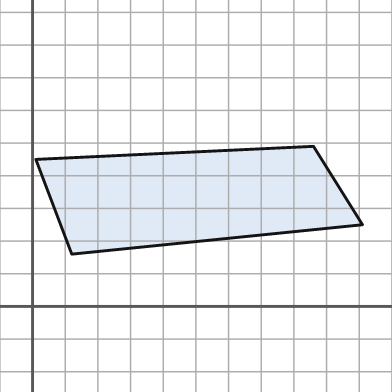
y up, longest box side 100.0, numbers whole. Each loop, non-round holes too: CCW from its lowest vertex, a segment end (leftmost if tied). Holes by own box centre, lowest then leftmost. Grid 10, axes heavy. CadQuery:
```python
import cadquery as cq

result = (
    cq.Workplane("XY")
    .moveTo(12.0, 16.0)
    .lineTo(101.0, 25.0)
    .lineTo(86.0, 49.0)
    .lineTo(1.0, 45.0)
    .close()
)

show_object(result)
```